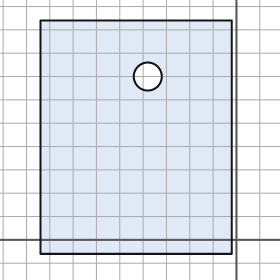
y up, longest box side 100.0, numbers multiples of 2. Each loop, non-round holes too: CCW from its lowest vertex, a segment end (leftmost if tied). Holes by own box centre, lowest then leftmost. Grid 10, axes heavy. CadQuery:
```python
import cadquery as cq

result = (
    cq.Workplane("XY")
    .moveTo(-84.0, -6.0)
    .lineTo(-2.0, -6.0)
    .lineTo(-2.0, 94.0)
    .lineTo(-84.0, 94.0)
    .close()
    .moveTo(-38.0, 70.0)
    .circle(6.0)
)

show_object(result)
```